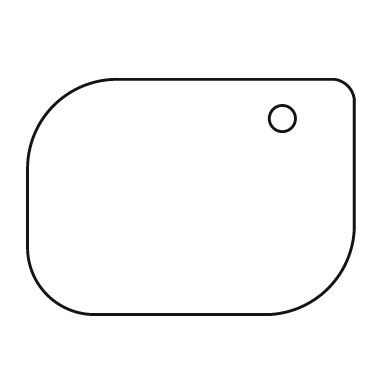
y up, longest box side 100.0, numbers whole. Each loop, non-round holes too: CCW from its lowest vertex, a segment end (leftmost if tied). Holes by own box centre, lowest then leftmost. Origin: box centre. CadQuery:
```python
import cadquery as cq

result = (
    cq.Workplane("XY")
    .moveTo(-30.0, -36.0)
    .lineTo(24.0, -36.0)
    .threePointArc((42.0, -28.0), (50.0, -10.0))
    .lineTo(50.0, 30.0)
    .threePointArc((48.0, 34.0), (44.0, 36.0))
    .lineTo(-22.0, 36.0)
    .threePointArc((-42.0, 28.0), (-50.0, 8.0))
    .lineTo(-50.0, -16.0)
    .threePointArc((-44.0, -30.0), (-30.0, -36.0))
    .close()
    .moveTo(28.0, 24.0)
    .circle(4.0)
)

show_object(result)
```